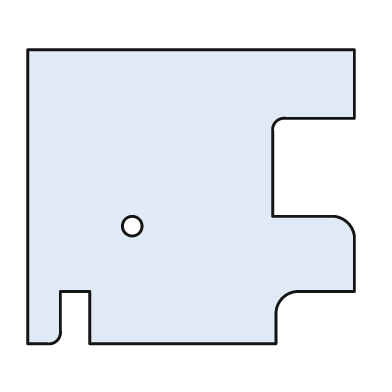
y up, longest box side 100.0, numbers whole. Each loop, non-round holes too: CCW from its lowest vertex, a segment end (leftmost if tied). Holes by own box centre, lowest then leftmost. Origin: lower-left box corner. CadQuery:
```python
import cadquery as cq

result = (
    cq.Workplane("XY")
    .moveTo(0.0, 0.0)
    .lineTo(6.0, 0.0)
    .threePointArc((9.0, 1.0), (10.0, 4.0))
    .lineTo(10.0, 16.0)
    .lineTo(19.0, 16.0)
    .lineTo(19.0, 0.0)
    .lineTo(76.0, 0.0)
    .lineTo(76.0, 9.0)
    .threePointArc((78.0, 14.0), (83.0, 16.0))
    .lineTo(100.0, 16.0)
    .lineTo(100.0, 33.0)
    .threePointArc((98.0, 37.0), (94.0, 39.0))
    .lineTo(75.0, 39.0)
    .lineTo(75.0, 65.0)
    .threePointArc((76.0, 68.0), (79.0, 69.0))
    .lineTo(100.0, 69.0)
    .lineTo(100.0, 90.0)
    .lineTo(0.0, 90.0)
    .close()
    .moveTo(32.0, 36.0)
    .circle(3.0)
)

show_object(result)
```